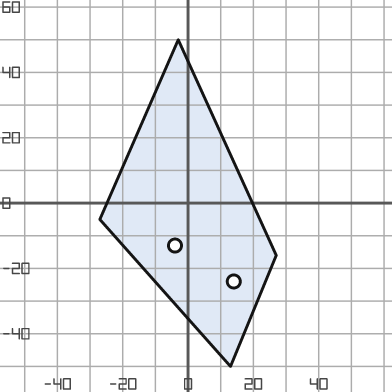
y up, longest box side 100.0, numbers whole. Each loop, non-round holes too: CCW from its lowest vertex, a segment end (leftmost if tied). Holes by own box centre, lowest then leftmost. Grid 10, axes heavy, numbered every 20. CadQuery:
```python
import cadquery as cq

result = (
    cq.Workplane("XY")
    .moveTo(13.0, -50.0)
    .lineTo(27.0, -16.0)
    .lineTo(-3.0, 50.0)
    .lineTo(-27.0, -5.0)
    .close()
    .moveTo(14.0, -24.0)
    .circle(2.0)
    .moveTo(-4.0, -13.0)
    .circle(2.0)
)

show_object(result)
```